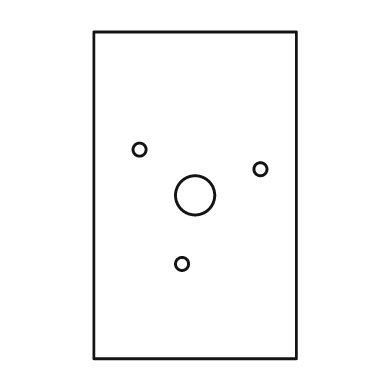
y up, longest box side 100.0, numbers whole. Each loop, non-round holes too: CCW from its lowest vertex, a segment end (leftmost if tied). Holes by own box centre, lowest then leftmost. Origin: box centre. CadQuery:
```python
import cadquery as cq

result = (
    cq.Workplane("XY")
    .moveTo(-31.0, -50.0)
    .lineTo(31.0, -50.0)
    .lineTo(31.0, 50.0)
    .lineTo(-31.0, 50.0)
    .close()
    .moveTo(-4.0, -21.0)
    .circle(2.0)
    .moveTo(0.0, 0.0)
    .circle(6.0)
    .moveTo(20.0, 8.0)
    .circle(2.0)
    .moveTo(-17.0, 14.0)
    .circle(2.0)
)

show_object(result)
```